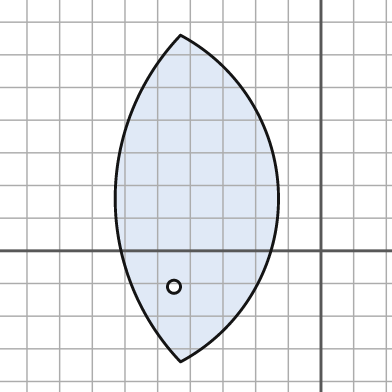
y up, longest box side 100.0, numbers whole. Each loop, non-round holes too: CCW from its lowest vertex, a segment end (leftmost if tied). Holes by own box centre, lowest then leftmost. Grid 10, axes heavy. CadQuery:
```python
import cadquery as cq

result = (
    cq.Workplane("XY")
    .moveTo(-43.0, -34.0)
    .threePointArc((-13.0, 16.0), (-43.0, 66.0))
    .threePointArc((-63.0, 16.0), (-43.0, -34.0))
    .close()
    .moveTo(-45.0, -11.0)
    .circle(2.0)
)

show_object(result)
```